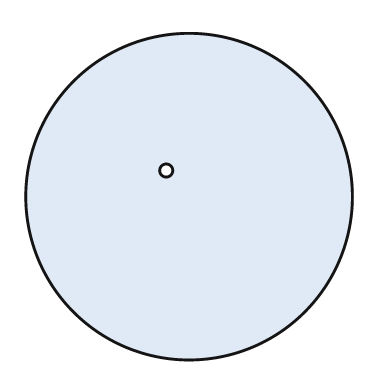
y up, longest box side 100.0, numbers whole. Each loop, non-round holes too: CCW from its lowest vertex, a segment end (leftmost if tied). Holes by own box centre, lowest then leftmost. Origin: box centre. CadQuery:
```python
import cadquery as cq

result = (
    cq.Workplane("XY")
    .moveTo(0.0, 0.0)
    .circle(50.0)
    .moveTo(-7.0, 8.0)
    .circle(2.0)
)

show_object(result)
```